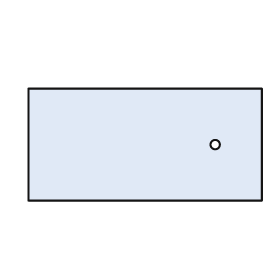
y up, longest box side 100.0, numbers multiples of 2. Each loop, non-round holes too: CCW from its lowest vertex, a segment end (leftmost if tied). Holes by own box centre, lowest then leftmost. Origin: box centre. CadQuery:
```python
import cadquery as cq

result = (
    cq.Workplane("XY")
    .moveTo(-50.0, -24.0)
    .lineTo(50.0, -24.0)
    .lineTo(50.0, 24.0)
    .lineTo(-50.0, 24.0)
    .close()
    .moveTo(30.0, 0.0)
    .circle(2.0)
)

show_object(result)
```